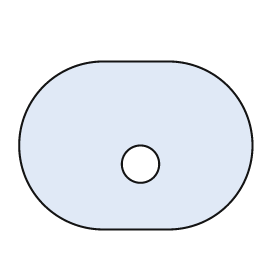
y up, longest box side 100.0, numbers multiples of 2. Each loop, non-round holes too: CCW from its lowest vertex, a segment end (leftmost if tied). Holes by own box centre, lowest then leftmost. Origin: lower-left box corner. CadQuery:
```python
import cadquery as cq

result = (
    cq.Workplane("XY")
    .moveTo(36.0, 0.0)
    .lineTo(64.0, 0.0)
    .threePointArc((100.0, 36.0), (64.0, 72.0))
    .lineTo(36.0, 72.0)
    .threePointArc((0.0, 36.0), (36.0, 0.0))
    .close()
    .moveTo(52.0, 28.0)
    .circle(8.0)
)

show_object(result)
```